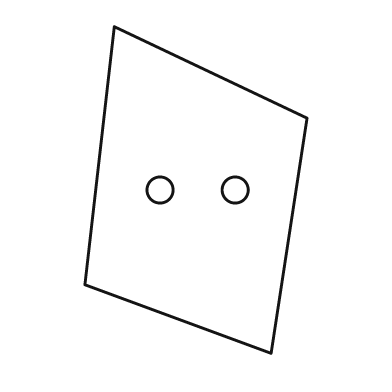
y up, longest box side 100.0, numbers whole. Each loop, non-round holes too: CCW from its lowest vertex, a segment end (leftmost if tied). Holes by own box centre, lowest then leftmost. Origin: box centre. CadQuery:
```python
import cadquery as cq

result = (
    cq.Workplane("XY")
    .moveTo(23.0, -50.0)
    .lineTo(34.0, 22.0)
    .lineTo(-25.0, 50.0)
    .lineTo(-34.0, -29.0)
    .close()
    .moveTo(-11.0, 0.0)
    .circle(4.0)
    .moveTo(12.0, 0.0)
    .circle(4.0)
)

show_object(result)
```